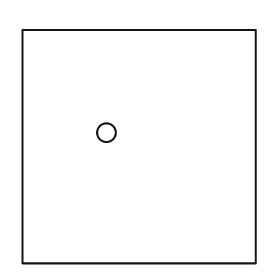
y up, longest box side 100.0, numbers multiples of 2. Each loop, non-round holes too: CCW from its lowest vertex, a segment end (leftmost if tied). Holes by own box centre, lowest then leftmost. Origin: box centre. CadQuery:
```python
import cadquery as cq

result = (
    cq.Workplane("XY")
    .moveTo(-50.0, -50.0)
    .lineTo(50.0, -50.0)
    .lineTo(50.0, 50.0)
    .lineTo(-50.0, 50.0)
    .close()
    .moveTo(-14.0, 6.0)
    .circle(4.0)
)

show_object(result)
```